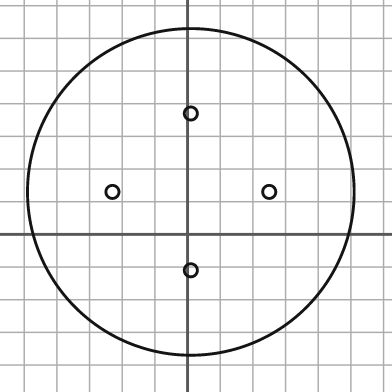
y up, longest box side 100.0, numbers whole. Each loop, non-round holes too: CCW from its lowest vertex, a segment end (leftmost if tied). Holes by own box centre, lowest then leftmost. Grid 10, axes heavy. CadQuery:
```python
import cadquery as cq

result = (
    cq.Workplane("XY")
    .moveTo(1.0, 13.0)
    .circle(50.0)
    .moveTo(1.0, -11.0)
    .circle(2.0)
    .moveTo(-23.0, 13.0)
    .circle(2.0)
    .moveTo(25.0, 13.0)
    .circle(2.0)
    .moveTo(1.0, 37.0)
    .circle(2.0)
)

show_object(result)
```